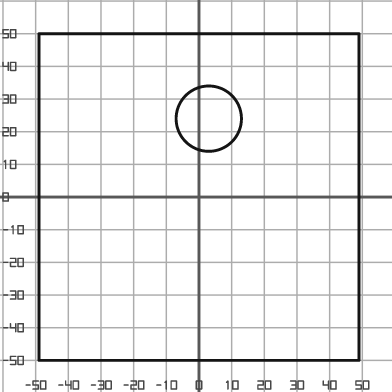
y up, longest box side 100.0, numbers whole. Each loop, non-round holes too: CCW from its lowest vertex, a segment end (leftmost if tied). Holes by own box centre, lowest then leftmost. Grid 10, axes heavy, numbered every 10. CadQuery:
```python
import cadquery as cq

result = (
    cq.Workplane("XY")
    .moveTo(-49.0, -50.0)
    .lineTo(49.0, -50.0)
    .lineTo(49.0, 50.0)
    .lineTo(-49.0, 50.0)
    .close()
    .moveTo(3.0, 24.0)
    .circle(10.0)
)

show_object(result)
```